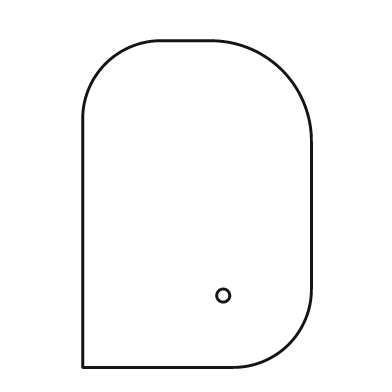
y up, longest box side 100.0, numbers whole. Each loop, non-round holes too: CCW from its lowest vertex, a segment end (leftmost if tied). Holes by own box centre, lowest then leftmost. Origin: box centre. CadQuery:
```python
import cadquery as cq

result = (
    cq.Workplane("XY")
    .moveTo(-35.0, -50.0)
    .lineTo(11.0, -50.0)
    .threePointArc((28.0, -43.0), (35.0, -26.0))
    .lineTo(35.0, 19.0)
    .threePointArc((26.0, 41.0), (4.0, 50.0))
    .lineTo(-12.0, 50.0)
    .threePointArc((-28.0, 43.0), (-35.0, 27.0))
    .close()
    .moveTo(8.0, -28.0)
    .circle(2.0)
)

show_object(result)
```